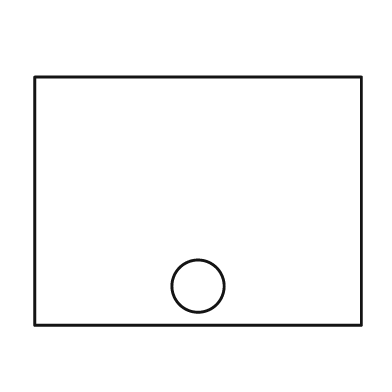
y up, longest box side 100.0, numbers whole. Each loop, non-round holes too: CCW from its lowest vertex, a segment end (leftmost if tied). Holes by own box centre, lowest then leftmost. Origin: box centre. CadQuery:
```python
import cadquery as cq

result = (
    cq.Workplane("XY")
    .moveTo(-50.0, -38.0)
    .lineTo(50.0, -38.0)
    .lineTo(50.0, 38.0)
    .lineTo(-50.0, 38.0)
    .close()
    .moveTo(0.0, -26.0)
    .circle(8.0)
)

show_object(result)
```